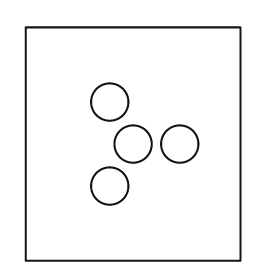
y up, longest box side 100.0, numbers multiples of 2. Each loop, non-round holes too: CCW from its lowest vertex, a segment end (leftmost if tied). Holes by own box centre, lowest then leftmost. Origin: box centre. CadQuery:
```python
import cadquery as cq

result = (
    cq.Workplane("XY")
    .moveTo(-46.0, -50.0)
    .lineTo(46.0, -50.0)
    .lineTo(46.0, 50.0)
    .lineTo(-46.0, 50.0)
    .close()
    .moveTo(-10.0, -18.0)
    .circle(8.0)
    .moveTo(0.0, 0.0)
    .circle(8.0)
    .moveTo(20.0, 0.0)
    .circle(8.0)
    .moveTo(-10.0, 18.0)
    .circle(8.0)
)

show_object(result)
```